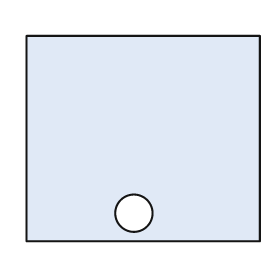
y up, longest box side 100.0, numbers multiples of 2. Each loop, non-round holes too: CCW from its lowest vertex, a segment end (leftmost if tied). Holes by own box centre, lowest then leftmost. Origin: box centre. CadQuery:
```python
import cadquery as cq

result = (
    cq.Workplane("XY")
    .moveTo(-50.0, -44.0)
    .lineTo(50.0, -44.0)
    .lineTo(50.0, 44.0)
    .lineTo(-50.0, 44.0)
    .close()
    .moveTo(-4.0, -32.0)
    .circle(8.0)
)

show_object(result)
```